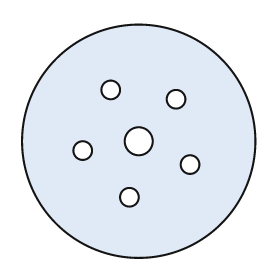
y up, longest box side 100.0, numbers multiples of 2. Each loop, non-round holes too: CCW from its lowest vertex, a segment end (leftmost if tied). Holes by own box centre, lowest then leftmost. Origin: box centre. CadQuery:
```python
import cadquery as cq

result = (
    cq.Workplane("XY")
    .moveTo(0.0, 0.0)
    .circle(50.0)
    .moveTo(-4.0, -24.0)
    .circle(4.0)
    .moveTo(22.0, -10.0)
    .circle(4.0)
    .moveTo(-24.0, -4.0)
    .circle(4.0)
    .moveTo(0.0, 0.0)
    .circle(6.0)
    .moveTo(16.0, 18.0)
    .circle(4.0)
    .moveTo(-12.0, 22.0)
    .circle(4.0)
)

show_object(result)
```